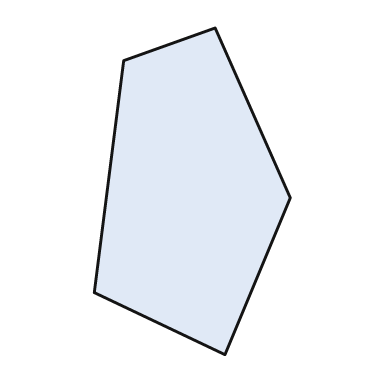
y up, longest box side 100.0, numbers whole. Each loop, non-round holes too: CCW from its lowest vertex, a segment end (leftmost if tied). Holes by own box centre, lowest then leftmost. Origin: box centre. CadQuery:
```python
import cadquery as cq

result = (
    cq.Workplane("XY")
    .moveTo(10.0, -50.0)
    .lineTo(30.0, -2.0)
    .lineTo(7.0, 50.0)
    .lineTo(-21.0, 40.0)
    .lineTo(-30.0, -31.0)
    .close()
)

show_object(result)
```